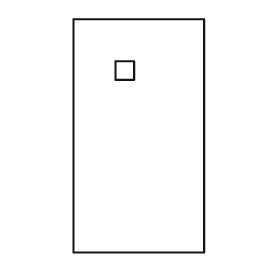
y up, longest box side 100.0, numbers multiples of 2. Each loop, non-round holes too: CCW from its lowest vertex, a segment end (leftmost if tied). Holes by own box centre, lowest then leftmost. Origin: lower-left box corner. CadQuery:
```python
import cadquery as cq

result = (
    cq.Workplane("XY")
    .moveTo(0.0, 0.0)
    .lineTo(56.0, 0.0)
    .lineTo(56.0, 100.0)
    .lineTo(0.0, 100.0)
    .close()
    .moveTo(18.0, 74.0)
    .lineTo(26.0, 74.0)
    .lineTo(26.0, 82.0)
    .lineTo(18.0, 82.0)
    .close()
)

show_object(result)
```